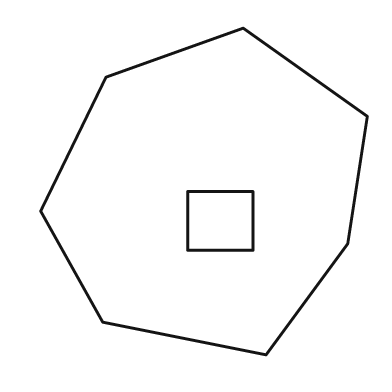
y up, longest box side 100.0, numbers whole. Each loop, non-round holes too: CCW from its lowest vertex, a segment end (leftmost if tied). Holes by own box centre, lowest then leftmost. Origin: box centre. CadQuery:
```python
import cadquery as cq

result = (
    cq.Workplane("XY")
    .moveTo(19.0, -50.0)
    .lineTo(44.0, -16.0)
    .lineTo(50.0, 23.0)
    .lineTo(12.0, 50.0)
    .lineTo(-30.0, 35.0)
    .lineTo(-50.0, -6.0)
    .lineTo(-31.0, -40.0)
    .close()
    .moveTo(-5.0, -18.0)
    .lineTo(15.0, -18.0)
    .lineTo(15.0, 0.0)
    .lineTo(-5.0, 0.0)
    .close()
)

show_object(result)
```